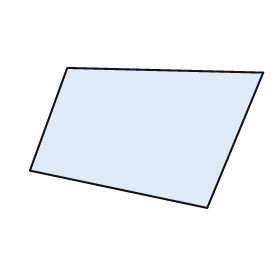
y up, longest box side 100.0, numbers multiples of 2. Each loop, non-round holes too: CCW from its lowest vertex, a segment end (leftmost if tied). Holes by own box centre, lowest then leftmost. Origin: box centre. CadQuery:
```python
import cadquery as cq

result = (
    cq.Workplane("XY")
    .moveTo(26.0, -30.0)
    .lineTo(50.0, 28.0)
    .lineTo(-34.0, 30.0)
    .lineTo(-50.0, -14.0)
    .close()
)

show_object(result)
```